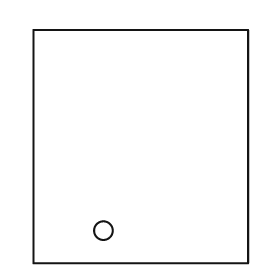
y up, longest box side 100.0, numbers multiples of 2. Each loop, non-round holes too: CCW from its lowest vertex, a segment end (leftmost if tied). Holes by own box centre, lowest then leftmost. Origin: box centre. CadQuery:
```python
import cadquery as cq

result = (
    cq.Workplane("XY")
    .moveTo(-46.0, -50.0)
    .lineTo(46.0, -50.0)
    .lineTo(46.0, 50.0)
    .lineTo(-46.0, 50.0)
    .close()
    .moveTo(-16.0, -36.0)
    .circle(4.0)
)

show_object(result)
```